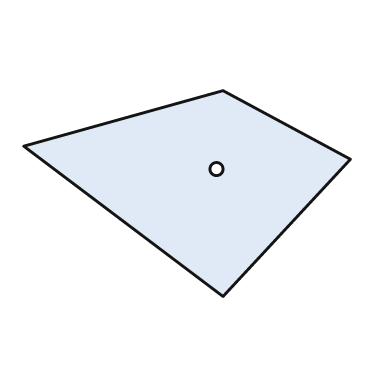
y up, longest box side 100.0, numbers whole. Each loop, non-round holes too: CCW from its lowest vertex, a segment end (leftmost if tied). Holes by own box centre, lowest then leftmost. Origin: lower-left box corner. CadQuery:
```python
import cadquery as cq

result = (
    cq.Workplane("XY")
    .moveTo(61.0, 0.0)
    .lineTo(100.0, 42.0)
    .lineTo(61.0, 63.0)
    .lineTo(0.0, 46.0)
    .close()
    .moveTo(59.0, 39.0)
    .circle(2.0)
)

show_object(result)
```